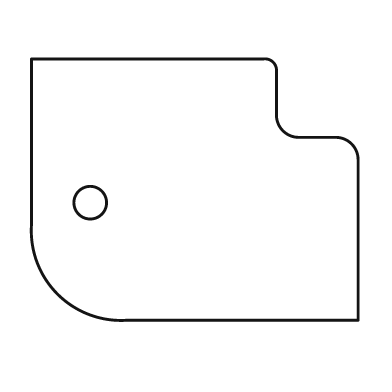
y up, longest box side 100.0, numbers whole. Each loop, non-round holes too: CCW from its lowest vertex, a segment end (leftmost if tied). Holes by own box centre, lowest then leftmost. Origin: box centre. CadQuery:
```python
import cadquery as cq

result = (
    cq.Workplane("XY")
    .moveTo(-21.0, -40.0)
    .lineTo(50.0, -40.0)
    .lineTo(50.0, 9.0)
    .threePointArc((48.0, 14.0), (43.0, 16.0))
    .lineTo(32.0, 16.0)
    .threePointArc((27.0, 18.0), (25.0, 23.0))
    .lineTo(25.0, 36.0)
    .threePointArc((24.0, 39.0), (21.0, 40.0))
    .lineTo(-50.0, 40.0)
    .lineTo(-50.0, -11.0)
    .threePointArc((-42.0, -32.0), (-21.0, -40.0))
    .close()
    .moveTo(-32.0, -4.0)
    .circle(5.0)
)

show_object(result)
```